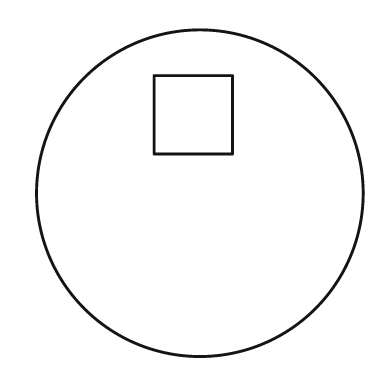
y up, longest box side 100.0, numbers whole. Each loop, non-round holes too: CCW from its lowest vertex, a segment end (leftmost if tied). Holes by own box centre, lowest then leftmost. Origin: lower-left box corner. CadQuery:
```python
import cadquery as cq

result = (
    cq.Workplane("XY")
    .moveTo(50.0, 50.0)
    .circle(50.0)
    .moveTo(36.0, 62.0)
    .lineTo(60.0, 62.0)
    .lineTo(60.0, 86.0)
    .lineTo(36.0, 86.0)
    .close()
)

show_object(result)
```